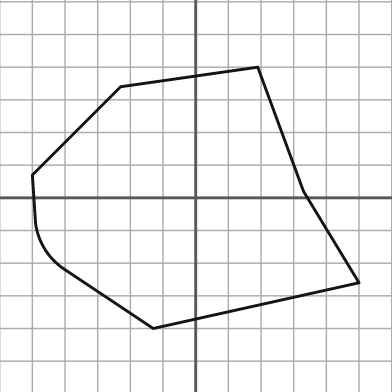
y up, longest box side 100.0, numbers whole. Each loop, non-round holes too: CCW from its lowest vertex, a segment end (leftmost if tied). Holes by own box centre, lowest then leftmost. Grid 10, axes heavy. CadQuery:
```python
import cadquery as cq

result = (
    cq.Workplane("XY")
    .moveTo(-13.0, -40.0)
    .lineTo(50.0, -26.0)
    .lineTo(33.0, 2.0)
    .lineTo(19.0, 40.0)
    .lineTo(-23.0, 34.0)
    .lineTo(-50.0, 7.0)
    .lineTo(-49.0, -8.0)
    .threePointArc((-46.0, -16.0), (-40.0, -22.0))
    .close()
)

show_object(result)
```